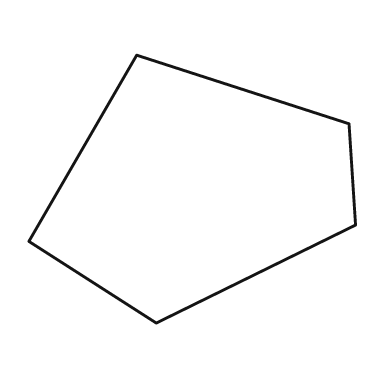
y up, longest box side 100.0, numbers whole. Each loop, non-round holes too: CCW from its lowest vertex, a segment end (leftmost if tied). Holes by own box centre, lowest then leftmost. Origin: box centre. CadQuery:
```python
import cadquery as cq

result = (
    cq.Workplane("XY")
    .moveTo(-11.0, -41.0)
    .lineTo(50.0, -11.0)
    .lineTo(48.0, 20.0)
    .lineTo(-17.0, 41.0)
    .lineTo(-50.0, -16.0)
    .close()
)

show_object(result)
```